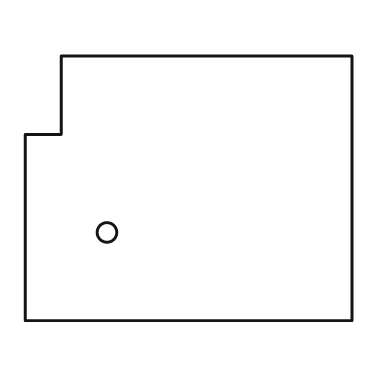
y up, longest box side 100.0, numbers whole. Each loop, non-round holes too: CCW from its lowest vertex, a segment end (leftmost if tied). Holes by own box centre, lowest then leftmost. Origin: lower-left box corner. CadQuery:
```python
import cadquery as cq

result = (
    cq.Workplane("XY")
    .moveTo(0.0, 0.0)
    .lineTo(100.0, 0.0)
    .lineTo(100.0, 81.0)
    .lineTo(11.0, 81.0)
    .lineTo(11.0, 57.0)
    .lineTo(0.0, 57.0)
    .close()
    .moveTo(25.0, 27.0)
    .circle(3.0)
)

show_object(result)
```